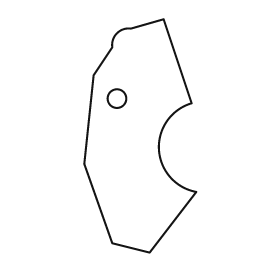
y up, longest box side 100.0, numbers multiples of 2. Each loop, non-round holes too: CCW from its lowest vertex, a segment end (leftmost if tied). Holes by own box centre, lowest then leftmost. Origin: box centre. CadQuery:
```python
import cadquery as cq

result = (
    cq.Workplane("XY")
    .moveTo(4.0, -50.0)
    .lineTo(24.0, -24.0)
    .threePointArc((8.0, -6.0), (22.0, 14.0))
    .lineTo(10.0, 50.0)
    .lineTo(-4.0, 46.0)
    .threePointArc((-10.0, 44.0), (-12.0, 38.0))
    .lineTo(-20.0, 26.0)
    .lineTo(-24.0, -12.0)
    .lineTo(-12.0, -46.0)
    .close()
    .moveTo(-10.0, 16.0)
    .circle(4.0)
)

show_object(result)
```